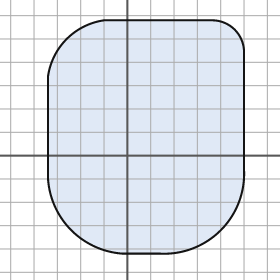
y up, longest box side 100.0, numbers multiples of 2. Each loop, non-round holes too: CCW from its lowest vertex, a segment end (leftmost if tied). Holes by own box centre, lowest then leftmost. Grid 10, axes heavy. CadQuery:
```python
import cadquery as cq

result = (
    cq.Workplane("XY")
    .moveTo(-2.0, -42.0)
    .lineTo(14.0, -42.0)
    .threePointArc((40.0, -32.0), (50.0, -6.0))
    .lineTo(50.0, 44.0)
    .threePointArc((46.0, 54.0), (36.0, 58.0))
    .lineTo(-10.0, 58.0)
    .threePointArc((-26.0, 50.0), (-34.0, 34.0))
    .lineTo(-34.0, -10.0)
    .threePointArc((-24.0, -32.0), (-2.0, -42.0))
    .close()
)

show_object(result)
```